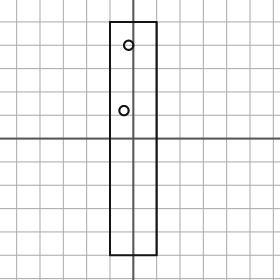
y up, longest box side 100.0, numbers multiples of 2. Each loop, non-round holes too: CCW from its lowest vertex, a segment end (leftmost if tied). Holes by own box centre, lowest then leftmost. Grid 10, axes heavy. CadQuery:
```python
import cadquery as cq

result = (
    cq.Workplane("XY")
    .moveTo(-10.0, -50.0)
    .lineTo(10.0, -50.0)
    .lineTo(10.0, 50.0)
    .lineTo(-10.0, 50.0)
    .close()
    .moveTo(-4.0, 12.0)
    .circle(2.0)
    .moveTo(-2.0, 40.0)
    .circle(2.0)
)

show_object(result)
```